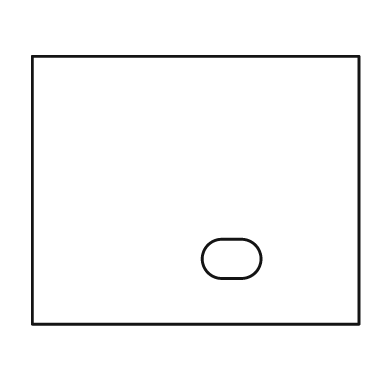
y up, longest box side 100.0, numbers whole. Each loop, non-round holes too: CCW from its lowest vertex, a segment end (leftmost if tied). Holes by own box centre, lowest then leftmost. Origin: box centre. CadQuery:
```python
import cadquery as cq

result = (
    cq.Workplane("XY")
    .moveTo(-50.0, -41.0)
    .lineTo(50.0, -41.0)
    .lineTo(50.0, 41.0)
    .lineTo(-50.0, 41.0)
    .close()
    .moveTo(8.0, -27.0)
    .lineTo(14.0, -27.0)
    .threePointArc((20.0, -21.0), (14.0, -15.0))
    .lineTo(8.0, -15.0)
    .threePointArc((2.0, -21.0), (8.0, -27.0))
    .close()
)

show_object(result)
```